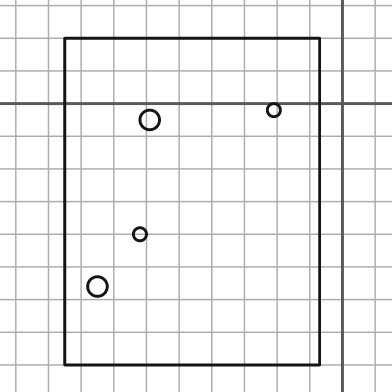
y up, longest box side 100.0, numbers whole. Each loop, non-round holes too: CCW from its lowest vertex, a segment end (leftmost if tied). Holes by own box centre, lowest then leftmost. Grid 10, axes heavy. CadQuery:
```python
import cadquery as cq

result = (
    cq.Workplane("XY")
    .moveTo(-85.0, -80.0)
    .lineTo(-7.0, -80.0)
    .lineTo(-7.0, 20.0)
    .lineTo(-85.0, 20.0)
    .close()
    .moveTo(-75.0, -56.0)
    .circle(3.0)
    .moveTo(-62.0, -40.0)
    .circle(2.0)
    .moveTo(-59.0, -5.0)
    .circle(3.0)
    .moveTo(-21.0, -2.0)
    .circle(2.0)
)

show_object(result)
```